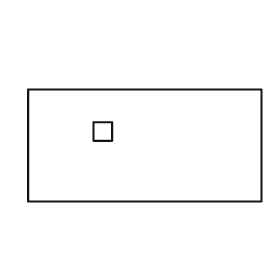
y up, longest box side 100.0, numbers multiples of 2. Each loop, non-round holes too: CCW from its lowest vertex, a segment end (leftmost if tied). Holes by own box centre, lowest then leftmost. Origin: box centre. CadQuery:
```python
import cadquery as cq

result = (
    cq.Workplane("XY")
    .moveTo(-50.0, -24.0)
    .lineTo(50.0, -24.0)
    .lineTo(50.0, 24.0)
    .lineTo(-50.0, 24.0)
    .close()
    .moveTo(-22.0, 2.0)
    .lineTo(-14.0, 2.0)
    .lineTo(-14.0, 10.0)
    .lineTo(-22.0, 10.0)
    .close()
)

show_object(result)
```